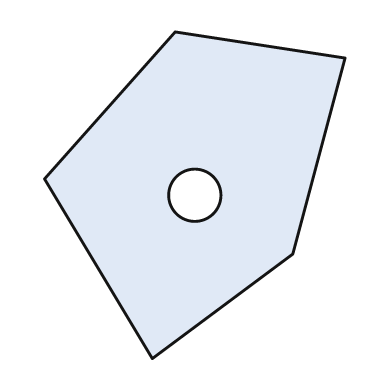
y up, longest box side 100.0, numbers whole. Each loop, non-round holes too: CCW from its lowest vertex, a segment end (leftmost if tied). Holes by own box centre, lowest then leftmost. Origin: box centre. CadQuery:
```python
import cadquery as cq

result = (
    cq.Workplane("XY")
    .moveTo(-13.0, -50.0)
    .lineTo(30.0, -18.0)
    .lineTo(46.0, 42.0)
    .lineTo(-6.0, 50.0)
    .lineTo(-46.0, 5.0)
    .close()
    .moveTo(0.0, 0.0)
    .circle(8.0)
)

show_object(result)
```